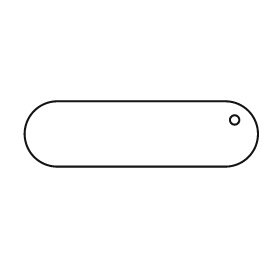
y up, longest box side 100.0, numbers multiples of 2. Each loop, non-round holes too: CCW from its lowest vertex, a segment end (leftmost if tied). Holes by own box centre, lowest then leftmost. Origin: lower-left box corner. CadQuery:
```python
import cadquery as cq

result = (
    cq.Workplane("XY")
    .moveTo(14.0, 0.0)
    .lineTo(86.0, 0.0)
    .threePointArc((100.0, 14.0), (86.0, 28.0))
    .lineTo(14.0, 28.0)
    .threePointArc((0.0, 14.0), (14.0, 0.0))
    .close()
    .moveTo(90.0, 20.0)
    .circle(2.0)
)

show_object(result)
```